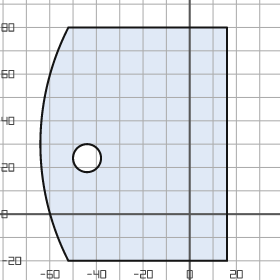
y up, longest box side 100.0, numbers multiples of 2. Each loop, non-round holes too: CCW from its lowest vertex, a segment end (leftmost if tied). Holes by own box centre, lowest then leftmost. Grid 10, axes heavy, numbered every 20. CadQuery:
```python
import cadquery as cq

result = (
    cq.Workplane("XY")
    .moveTo(-52.0, -20.0)
    .lineTo(16.0, -20.0)
    .lineTo(16.0, 80.0)
    .lineTo(-52.0, 80.0)
    .threePointArc((-64.0, 30.0), (-52.0, -20.0))
    .close()
    .moveTo(-44.0, 24.0)
    .circle(6.0)
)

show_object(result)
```